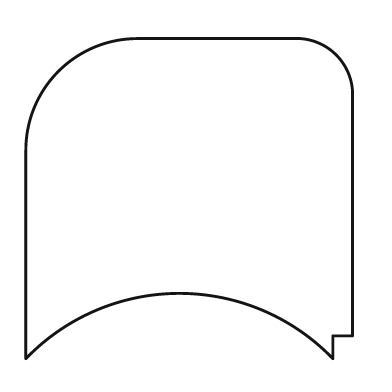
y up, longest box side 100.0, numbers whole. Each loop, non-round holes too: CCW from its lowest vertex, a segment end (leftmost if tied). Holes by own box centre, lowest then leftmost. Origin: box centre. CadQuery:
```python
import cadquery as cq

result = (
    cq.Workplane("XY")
    .moveTo(-50.0, -49.0)
    .threePointArc((-3.0, -29.0), (44.0, -49.0))
    .lineTo(44.0, -42.0)
    .lineTo(50.0, -42.0)
    .lineTo(50.0, 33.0)
    .threePointArc((45.0, 44.0), (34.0, 49.0))
    .lineTo(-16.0, 49.0)
    .threePointArc((-40.0, 39.0), (-50.0, 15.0))
    .close()
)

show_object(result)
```